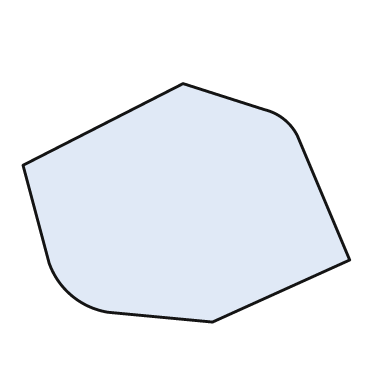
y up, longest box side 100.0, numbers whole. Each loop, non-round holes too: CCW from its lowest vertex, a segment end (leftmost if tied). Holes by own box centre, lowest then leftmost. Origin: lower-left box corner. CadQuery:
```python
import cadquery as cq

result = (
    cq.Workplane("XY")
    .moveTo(58.0, 0.0)
    .lineTo(100.0, 19.0)
    .lineTo(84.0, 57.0)
    .threePointArc((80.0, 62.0), (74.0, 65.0))
    .lineTo(49.0, 73.0)
    .lineTo(0.0, 48.0)
    .lineTo(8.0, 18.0)
    .threePointArc((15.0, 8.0), (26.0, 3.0))
    .close()
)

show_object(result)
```